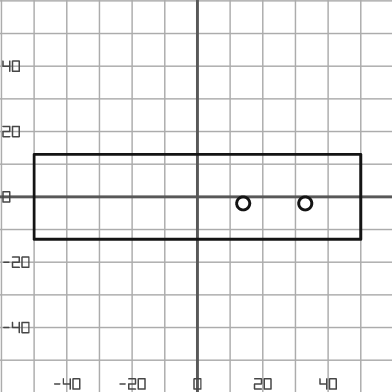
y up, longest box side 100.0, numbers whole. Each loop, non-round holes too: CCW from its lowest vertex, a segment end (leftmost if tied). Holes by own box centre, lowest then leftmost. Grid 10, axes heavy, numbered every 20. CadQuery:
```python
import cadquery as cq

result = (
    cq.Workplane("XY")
    .moveTo(-50.0, -13.0)
    .lineTo(50.0, -13.0)
    .lineTo(50.0, 13.0)
    .lineTo(-50.0, 13.0)
    .close()
    .moveTo(14.0, -2.0)
    .circle(2.0)
    .moveTo(33.0, -2.0)
    .circle(2.0)
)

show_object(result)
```